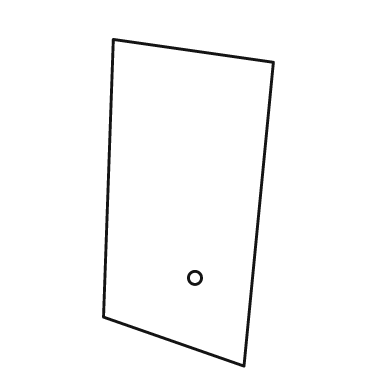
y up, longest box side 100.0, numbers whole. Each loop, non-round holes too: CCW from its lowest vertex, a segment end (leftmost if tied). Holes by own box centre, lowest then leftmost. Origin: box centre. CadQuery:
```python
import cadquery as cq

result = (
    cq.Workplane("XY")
    .moveTo(17.0, -50.0)
    .lineTo(26.0, 43.0)
    .lineTo(-23.0, 50.0)
    .lineTo(-26.0, -35.0)
    .close()
    .moveTo(2.0, -23.0)
    .circle(2.0)
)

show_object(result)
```